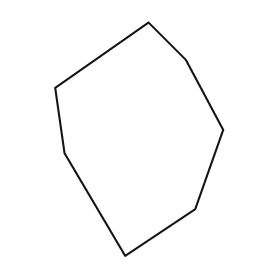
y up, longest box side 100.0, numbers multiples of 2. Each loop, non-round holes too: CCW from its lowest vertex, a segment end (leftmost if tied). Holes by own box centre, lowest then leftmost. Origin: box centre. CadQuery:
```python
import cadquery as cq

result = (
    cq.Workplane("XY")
    .moveTo(-6.0, -50.0)
    .lineTo(24.0, -30.0)
    .lineTo(36.0, 4.0)
    .lineTo(20.0, 34.0)
    .lineTo(4.0, 50.0)
    .lineTo(-36.0, 22.0)
    .lineTo(-32.0, -6.0)
    .close()
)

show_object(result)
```